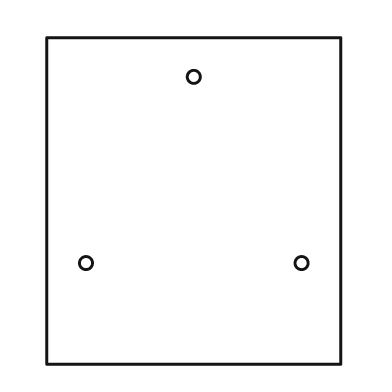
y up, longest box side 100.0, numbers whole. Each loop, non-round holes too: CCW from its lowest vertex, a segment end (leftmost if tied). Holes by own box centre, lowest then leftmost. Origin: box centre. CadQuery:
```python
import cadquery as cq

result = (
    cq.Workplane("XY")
    .moveTo(-45.0, -50.0)
    .lineTo(45.0, -50.0)
    .lineTo(45.0, 50.0)
    .lineTo(-45.0, 50.0)
    .close()
    .moveTo(-33.0, -19.0)
    .circle(2.0)
    .moveTo(33.0, -19.0)
    .circle(2.0)
    .moveTo(0.0, 38.0)
    .circle(2.0)
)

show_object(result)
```